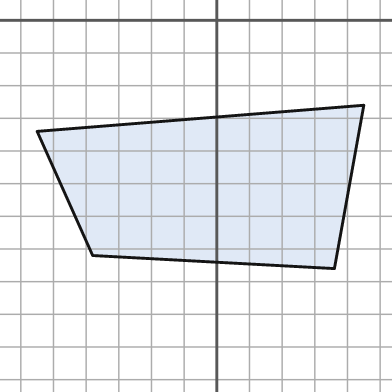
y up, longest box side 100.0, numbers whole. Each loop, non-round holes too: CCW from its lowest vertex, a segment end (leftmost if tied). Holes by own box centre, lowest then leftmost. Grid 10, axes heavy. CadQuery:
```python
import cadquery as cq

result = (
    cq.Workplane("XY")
    .moveTo(36.0, -76.0)
    .lineTo(45.0, -26.0)
    .lineTo(-55.0, -34.0)
    .lineTo(-38.0, -72.0)
    .close()
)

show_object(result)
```